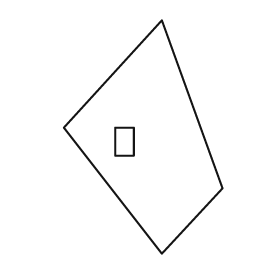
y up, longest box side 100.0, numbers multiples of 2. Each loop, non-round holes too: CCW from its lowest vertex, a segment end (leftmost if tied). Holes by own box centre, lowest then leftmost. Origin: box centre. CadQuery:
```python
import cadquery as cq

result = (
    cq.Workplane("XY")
    .moveTo(8.0, -50.0)
    .lineTo(34.0, -22.0)
    .lineTo(8.0, 50.0)
    .lineTo(-34.0, 4.0)
    .close()
    .moveTo(-12.0, -8.0)
    .lineTo(-4.0, -8.0)
    .lineTo(-4.0, 4.0)
    .lineTo(-12.0, 4.0)
    .close()
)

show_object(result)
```